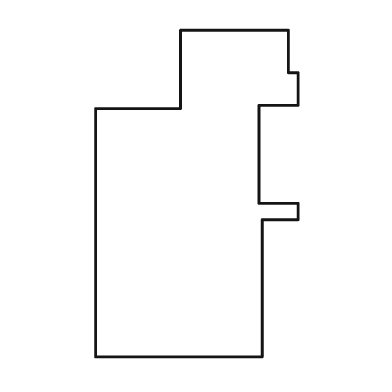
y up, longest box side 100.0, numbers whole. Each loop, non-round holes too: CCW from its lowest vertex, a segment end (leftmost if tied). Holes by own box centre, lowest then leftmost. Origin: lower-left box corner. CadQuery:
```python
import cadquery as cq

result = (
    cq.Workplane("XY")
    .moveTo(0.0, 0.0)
    .lineTo(51.0, 0.0)
    .lineTo(51.0, 42.0)
    .lineTo(62.0, 42.0)
    .lineTo(62.0, 47.0)
    .lineTo(50.0, 47.0)
    .lineTo(50.0, 77.0)
    .lineTo(62.0, 77.0)
    .lineTo(62.0, 87.0)
    .lineTo(59.0, 87.0)
    .lineTo(59.0, 100.0)
    .lineTo(26.0, 100.0)
    .lineTo(26.0, 76.0)
    .lineTo(0.0, 76.0)
    .close()
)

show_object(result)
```